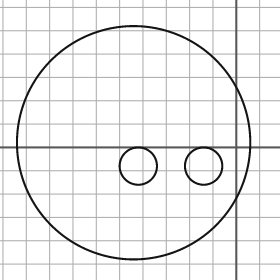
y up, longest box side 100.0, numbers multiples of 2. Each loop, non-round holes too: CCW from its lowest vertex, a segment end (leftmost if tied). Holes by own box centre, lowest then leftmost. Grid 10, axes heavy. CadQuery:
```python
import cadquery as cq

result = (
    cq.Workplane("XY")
    .moveTo(-44.0, 2.0)
    .circle(50.0)
    .moveTo(-42.0, -8.0)
    .circle(8.0)
    .moveTo(-14.0, -8.0)
    .circle(8.0)
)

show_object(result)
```